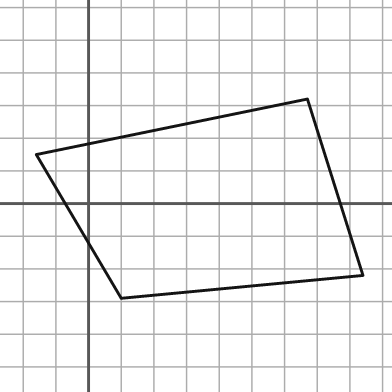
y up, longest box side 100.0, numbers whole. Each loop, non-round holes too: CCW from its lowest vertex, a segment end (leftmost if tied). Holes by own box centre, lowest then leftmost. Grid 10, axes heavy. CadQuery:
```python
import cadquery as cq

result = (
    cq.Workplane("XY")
    .moveTo(10.0, -29.0)
    .lineTo(84.0, -22.0)
    .lineTo(67.0, 32.0)
    .lineTo(-16.0, 15.0)
    .close()
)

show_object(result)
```